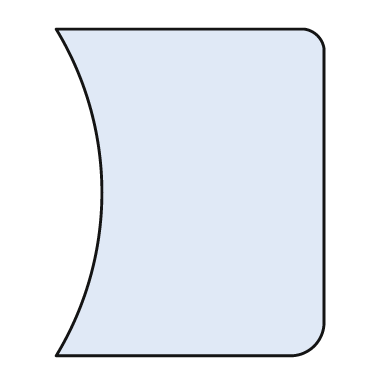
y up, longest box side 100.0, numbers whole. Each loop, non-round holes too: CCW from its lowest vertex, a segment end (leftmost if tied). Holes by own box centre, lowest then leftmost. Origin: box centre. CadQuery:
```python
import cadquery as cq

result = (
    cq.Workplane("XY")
    .moveTo(-41.0, -50.0)
    .lineTo(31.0, -50.0)
    .threePointArc((38.0, -47.0), (41.0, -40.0))
    .lineTo(41.0, 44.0)
    .threePointArc((39.0, 48.0), (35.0, 50.0))
    .lineTo(-41.0, 50.0)
    .threePointArc((-27.0, 0.0), (-41.0, -50.0))
    .close()
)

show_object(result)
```